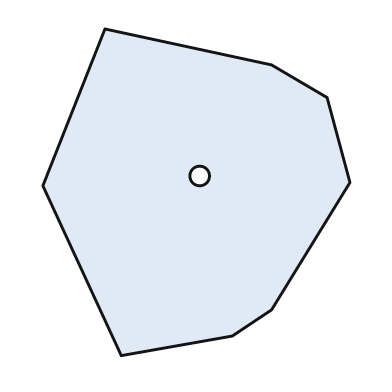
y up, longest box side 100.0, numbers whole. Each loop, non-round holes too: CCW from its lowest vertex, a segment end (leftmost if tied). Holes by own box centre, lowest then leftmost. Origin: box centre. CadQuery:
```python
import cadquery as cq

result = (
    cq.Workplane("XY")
    .moveTo(-23.0, -50.0)
    .lineTo(11.0, -44.0)
    .lineTo(23.0, -36.0)
    .lineTo(47.0, 3.0)
    .lineTo(40.0, 29.0)
    .lineTo(23.0, 39.0)
    .lineTo(-28.0, 50.0)
    .lineTo(-47.0, 2.0)
    .close()
    .moveTo(1.0, 5.0)
    .circle(3.0)
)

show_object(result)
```